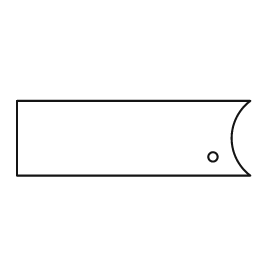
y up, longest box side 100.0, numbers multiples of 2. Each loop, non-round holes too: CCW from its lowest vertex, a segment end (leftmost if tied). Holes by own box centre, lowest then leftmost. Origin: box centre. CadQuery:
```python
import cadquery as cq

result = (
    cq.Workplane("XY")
    .moveTo(-50.0, -16.0)
    .lineTo(50.0, -16.0)
    .threePointArc((42.0, 0.0), (50.0, 16.0))
    .lineTo(-50.0, 16.0)
    .close()
    .moveTo(34.0, -8.0)
    .circle(2.0)
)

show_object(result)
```